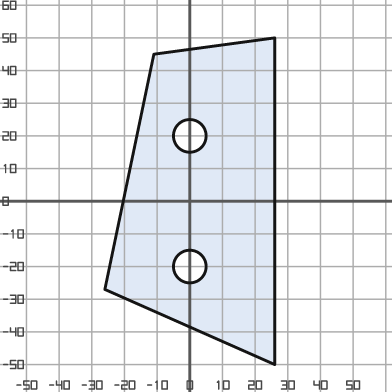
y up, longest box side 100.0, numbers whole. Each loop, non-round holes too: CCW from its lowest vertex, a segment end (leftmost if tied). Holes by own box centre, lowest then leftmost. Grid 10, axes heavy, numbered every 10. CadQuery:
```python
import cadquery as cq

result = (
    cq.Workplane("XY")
    .moveTo(26.0, -50.0)
    .lineTo(26.0, 50.0)
    .lineTo(-11.0, 45.0)
    .lineTo(-26.0, -27.0)
    .close()
    .moveTo(0.0, -20.0)
    .circle(5.0)
    .moveTo(0.0, 20.0)
    .circle(5.0)
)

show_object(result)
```